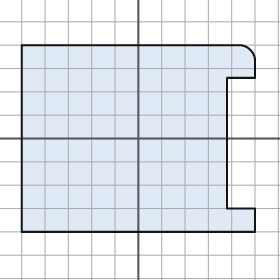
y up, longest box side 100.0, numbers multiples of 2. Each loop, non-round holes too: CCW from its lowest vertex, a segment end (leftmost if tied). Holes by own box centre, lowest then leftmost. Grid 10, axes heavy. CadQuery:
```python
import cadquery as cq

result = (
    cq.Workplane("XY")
    .moveTo(-50.0, -40.0)
    .lineTo(50.0, -40.0)
    .lineTo(50.0, -30.0)
    .lineTo(38.0, -30.0)
    .lineTo(38.0, 26.0)
    .lineTo(50.0, 26.0)
    .lineTo(50.0, 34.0)
    .threePointArc((48.0, 38.0), (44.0, 40.0))
    .lineTo(-50.0, 40.0)
    .close()
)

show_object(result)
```